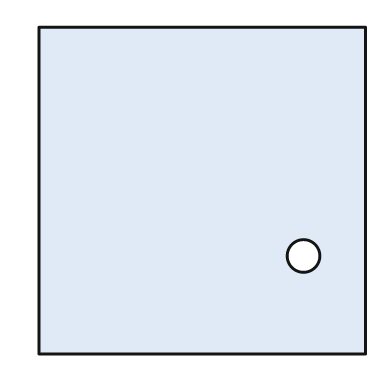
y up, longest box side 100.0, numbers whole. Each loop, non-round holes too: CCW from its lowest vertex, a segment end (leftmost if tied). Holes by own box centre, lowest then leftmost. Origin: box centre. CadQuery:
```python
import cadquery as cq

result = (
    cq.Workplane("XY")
    .moveTo(-50.0, -50.0)
    .lineTo(50.0, -50.0)
    .lineTo(50.0, 50.0)
    .lineTo(-50.0, 50.0)
    .close()
    .moveTo(31.0, -20.0)
    .circle(5.0)
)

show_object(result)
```